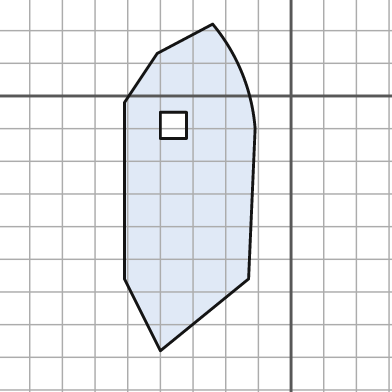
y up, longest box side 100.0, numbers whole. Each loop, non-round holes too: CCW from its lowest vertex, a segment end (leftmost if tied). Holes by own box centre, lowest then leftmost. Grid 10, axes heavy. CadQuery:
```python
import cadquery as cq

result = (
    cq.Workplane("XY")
    .moveTo(-40.0, -78.0)
    .lineTo(-13.0, -56.0)
    .lineTo(-11.0, -10.0)
    .threePointArc((-15.0, 7.0), (-24.0, 22.0))
    .lineTo(-41.0, 13.0)
    .lineTo(-51.0, -2.0)
    .lineTo(-51.0, -56.0)
    .close()
    .moveTo(-40.0, -13.0)
    .lineTo(-32.0, -13.0)
    .lineTo(-32.0, -5.0)
    .lineTo(-40.0, -5.0)
    .close()
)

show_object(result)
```